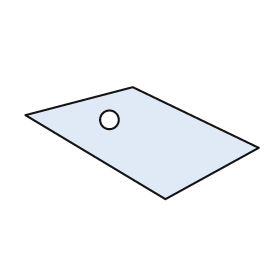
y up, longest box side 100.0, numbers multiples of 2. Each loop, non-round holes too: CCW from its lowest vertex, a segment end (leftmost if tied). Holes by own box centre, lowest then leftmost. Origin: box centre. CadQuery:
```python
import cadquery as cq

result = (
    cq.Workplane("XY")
    .moveTo(10.0, -24.0)
    .lineTo(50.0, -2.0)
    .lineTo(-4.0, 24.0)
    .lineTo(-50.0, 12.0)
    .close()
    .moveTo(-14.0, 10.0)
    .circle(4.0)
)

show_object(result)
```